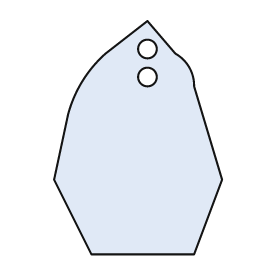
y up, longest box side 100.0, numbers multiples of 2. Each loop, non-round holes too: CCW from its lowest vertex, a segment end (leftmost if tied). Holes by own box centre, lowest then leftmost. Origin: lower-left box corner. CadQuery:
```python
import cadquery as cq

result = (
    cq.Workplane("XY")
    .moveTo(16.0, 0.0)
    .lineTo(60.0, 0.0)
    .lineTo(72.0, 32.0)
    .lineTo(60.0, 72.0)
    .threePointArc((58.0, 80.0), (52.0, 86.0))
    .lineTo(40.0, 100.0)
    .lineTo(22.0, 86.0)
    .threePointArc((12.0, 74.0), (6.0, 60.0))
    .lineTo(0.0, 32.0)
    .close()
    .moveTo(40.0, 76.0)
    .circle(4.0)
    .moveTo(40.0, 88.0)
    .circle(4.0)
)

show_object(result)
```